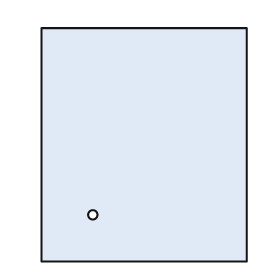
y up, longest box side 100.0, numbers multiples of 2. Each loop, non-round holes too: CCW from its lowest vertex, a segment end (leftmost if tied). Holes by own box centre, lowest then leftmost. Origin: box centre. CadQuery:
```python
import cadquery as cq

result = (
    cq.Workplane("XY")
    .moveTo(-44.0, -50.0)
    .lineTo(44.0, -50.0)
    .lineTo(44.0, 50.0)
    .lineTo(-44.0, 50.0)
    .close()
    .moveTo(-22.0, -30.0)
    .circle(2.0)
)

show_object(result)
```